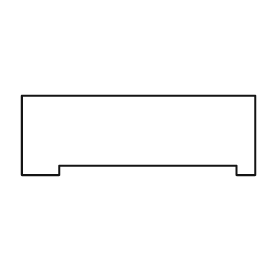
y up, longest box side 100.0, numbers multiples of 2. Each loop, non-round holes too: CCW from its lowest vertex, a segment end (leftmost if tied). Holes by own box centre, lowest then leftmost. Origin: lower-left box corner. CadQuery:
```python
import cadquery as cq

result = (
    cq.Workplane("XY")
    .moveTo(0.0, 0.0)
    .lineTo(16.0, 0.0)
    .lineTo(16.0, 4.0)
    .lineTo(92.0, 4.0)
    .lineTo(92.0, 0.0)
    .lineTo(100.0, 0.0)
    .lineTo(100.0, 34.0)
    .lineTo(0.0, 34.0)
    .close()
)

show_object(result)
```